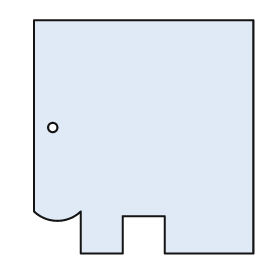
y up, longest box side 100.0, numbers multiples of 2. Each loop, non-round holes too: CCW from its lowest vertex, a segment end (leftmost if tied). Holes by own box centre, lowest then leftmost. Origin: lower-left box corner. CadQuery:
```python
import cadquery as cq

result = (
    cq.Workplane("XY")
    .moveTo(20.0, 0.0)
    .lineTo(38.0, 0.0)
    .lineTo(38.0, 16.0)
    .lineTo(56.0, 16.0)
    .lineTo(56.0, 0.0)
    .lineTo(94.0, 0.0)
    .lineTo(94.0, 100.0)
    .lineTo(0.0, 100.0)
    .lineTo(0.0, 18.0)
    .threePointArc((10.0, 14.0), (20.0, 18.0))
    .close()
    .moveTo(8.0, 54.0)
    .circle(2.0)
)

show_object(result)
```